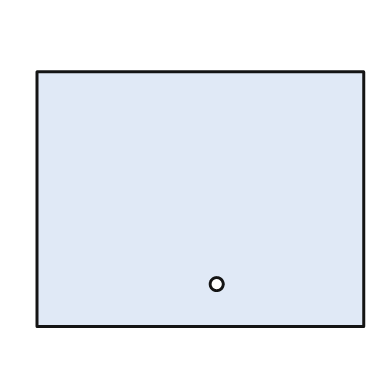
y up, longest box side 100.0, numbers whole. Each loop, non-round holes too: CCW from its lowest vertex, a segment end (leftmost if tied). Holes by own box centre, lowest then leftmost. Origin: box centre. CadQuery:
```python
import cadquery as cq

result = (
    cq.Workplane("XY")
    .moveTo(-50.0, -39.0)
    .lineTo(50.0, -39.0)
    .lineTo(50.0, 39.0)
    .lineTo(-50.0, 39.0)
    .close()
    .moveTo(5.0, -26.0)
    .circle(2.0)
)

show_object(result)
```